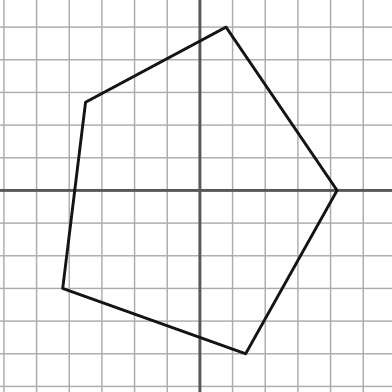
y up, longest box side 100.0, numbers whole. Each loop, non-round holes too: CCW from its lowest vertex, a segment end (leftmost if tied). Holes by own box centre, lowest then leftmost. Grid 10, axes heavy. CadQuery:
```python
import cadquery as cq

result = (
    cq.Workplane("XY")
    .moveTo(14.0, -50.0)
    .lineTo(42.0, 0.0)
    .lineTo(8.0, 50.0)
    .lineTo(-35.0, 27.0)
    .lineTo(-42.0, -30.0)
    .close()
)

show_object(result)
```